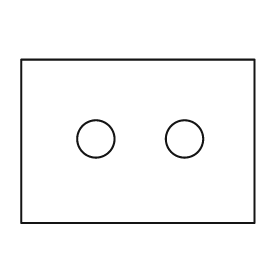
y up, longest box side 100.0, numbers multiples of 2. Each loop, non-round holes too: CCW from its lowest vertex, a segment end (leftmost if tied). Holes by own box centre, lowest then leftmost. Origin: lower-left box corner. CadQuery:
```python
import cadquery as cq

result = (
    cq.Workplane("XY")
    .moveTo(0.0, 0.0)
    .lineTo(100.0, 0.0)
    .lineTo(100.0, 70.0)
    .lineTo(0.0, 70.0)
    .close()
    .moveTo(32.0, 36.0)
    .circle(8.0)
    .moveTo(70.0, 36.0)
    .circle(8.0)
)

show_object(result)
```